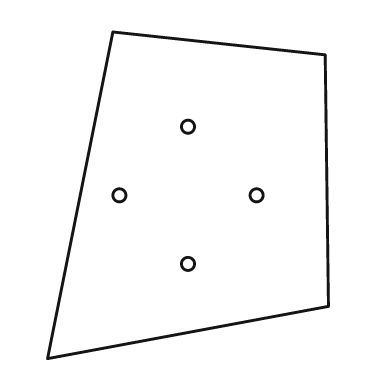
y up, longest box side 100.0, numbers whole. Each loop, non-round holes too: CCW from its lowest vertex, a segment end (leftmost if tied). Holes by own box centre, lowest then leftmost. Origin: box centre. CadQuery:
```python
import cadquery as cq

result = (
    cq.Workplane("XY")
    .moveTo(-43.0, -50.0)
    .lineTo(43.0, -34.0)
    .lineTo(42.0, 43.0)
    .lineTo(-23.0, 50.0)
    .close()
    .moveTo(0.0, -21.0)
    .circle(2.0)
    .moveTo(-21.0, 0.0)
    .circle(2.0)
    .moveTo(21.0, 0.0)
    .circle(2.0)
    .moveTo(0.0, 21.0)
    .circle(2.0)
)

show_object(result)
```